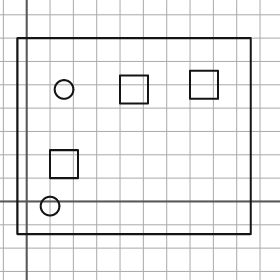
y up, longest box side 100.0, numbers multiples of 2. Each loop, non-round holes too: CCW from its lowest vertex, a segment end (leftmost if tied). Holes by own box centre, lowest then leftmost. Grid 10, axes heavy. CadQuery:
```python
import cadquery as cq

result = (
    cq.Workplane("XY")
    .moveTo(-4.0, -14.0)
    .lineTo(96.0, -14.0)
    .lineTo(96.0, 70.0)
    .lineTo(-4.0, 70.0)
    .close()
    .moveTo(10.0, -2.0)
    .circle(4.0)
    .moveTo(10.0, 10.0)
    .lineTo(22.0, 10.0)
    .lineTo(22.0, 22.0)
    .lineTo(10.0, 22.0)
    .close()
    .moveTo(16.0, 48.0)
    .circle(4.0)
    .moveTo(40.0, 42.0)
    .lineTo(52.0, 42.0)
    .lineTo(52.0, 54.0)
    .lineTo(40.0, 54.0)
    .close()
    .moveTo(70.0, 44.0)
    .lineTo(82.0, 44.0)
    .lineTo(82.0, 56.0)
    .lineTo(70.0, 56.0)
    .close()
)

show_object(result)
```